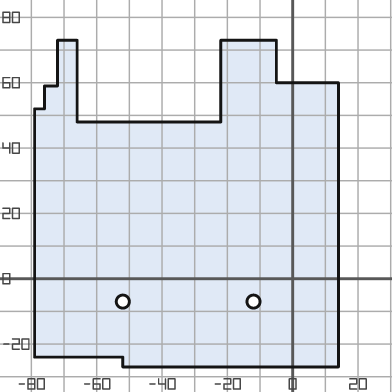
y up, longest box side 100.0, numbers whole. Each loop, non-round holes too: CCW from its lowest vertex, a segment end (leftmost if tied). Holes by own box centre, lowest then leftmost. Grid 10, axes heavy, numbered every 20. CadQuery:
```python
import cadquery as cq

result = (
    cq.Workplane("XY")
    .moveTo(-52.0, -27.0)
    .lineTo(14.0, -27.0)
    .lineTo(14.0, 60.0)
    .lineTo(-5.0, 60.0)
    .lineTo(-5.0, 73.0)
    .lineTo(-22.0, 73.0)
    .lineTo(-22.0, 48.0)
    .lineTo(-66.0, 48.0)
    .lineTo(-66.0, 73.0)
    .lineTo(-72.0, 73.0)
    .lineTo(-72.0, 59.0)
    .lineTo(-76.0, 59.0)
    .lineTo(-76.0, 52.0)
    .lineTo(-79.0, 52.0)
    .lineTo(-79.0, -24.0)
    .lineTo(-52.0, -24.0)
    .close()
    .moveTo(-52.0, -7.0)
    .circle(2.0)
    .moveTo(-12.0, -7.0)
    .circle(2.0)
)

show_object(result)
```